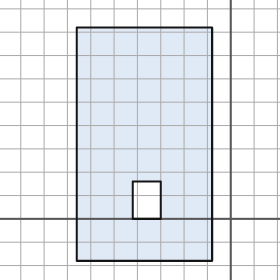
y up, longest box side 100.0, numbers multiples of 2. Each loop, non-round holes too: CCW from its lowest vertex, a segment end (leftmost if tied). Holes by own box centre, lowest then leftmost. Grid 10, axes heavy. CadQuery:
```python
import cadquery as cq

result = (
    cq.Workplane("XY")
    .moveTo(-66.0, -18.0)
    .lineTo(-8.0, -18.0)
    .lineTo(-8.0, 82.0)
    .lineTo(-66.0, 82.0)
    .close()
    .moveTo(-42.0, 0.0)
    .lineTo(-30.0, 0.0)
    .lineTo(-30.0, 16.0)
    .lineTo(-42.0, 16.0)
    .close()
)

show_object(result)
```